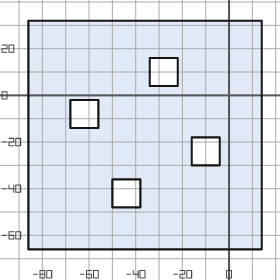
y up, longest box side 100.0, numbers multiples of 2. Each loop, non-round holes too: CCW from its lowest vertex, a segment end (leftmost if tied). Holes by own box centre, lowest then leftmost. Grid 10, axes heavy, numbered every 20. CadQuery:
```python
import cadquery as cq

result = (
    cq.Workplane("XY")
    .moveTo(-86.0, -66.0)
    .lineTo(14.0, -66.0)
    .lineTo(14.0, 32.0)
    .lineTo(-86.0, 32.0)
    .close()
    .moveTo(-50.0, -48.0)
    .lineTo(-38.0, -48.0)
    .lineTo(-38.0, -36.0)
    .lineTo(-50.0, -36.0)
    .close()
    .moveTo(-16.0, -30.0)
    .lineTo(-4.0, -30.0)
    .lineTo(-4.0, -18.0)
    .lineTo(-16.0, -18.0)
    .close()
    .moveTo(-68.0, -14.0)
    .lineTo(-56.0, -14.0)
    .lineTo(-56.0, -2.0)
    .lineTo(-68.0, -2.0)
    .close()
    .moveTo(-34.0, 4.0)
    .lineTo(-22.0, 4.0)
    .lineTo(-22.0, 16.0)
    .lineTo(-34.0, 16.0)
    .close()
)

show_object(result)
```